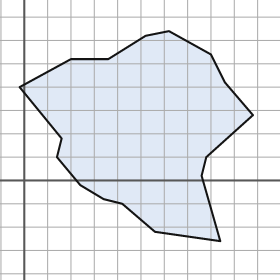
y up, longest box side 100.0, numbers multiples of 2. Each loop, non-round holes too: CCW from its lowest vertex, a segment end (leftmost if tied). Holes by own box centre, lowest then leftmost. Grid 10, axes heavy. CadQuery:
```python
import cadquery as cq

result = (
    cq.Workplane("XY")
    .moveTo(84.0, -26.0)
    .lineTo(76.0, 2.0)
    .lineTo(78.0, 10.0)
    .lineTo(98.0, 28.0)
    .lineTo(86.0, 42.0)
    .lineTo(80.0, 54.0)
    .lineTo(62.0, 64.0)
    .lineTo(52.0, 62.0)
    .lineTo(36.0, 52.0)
    .lineTo(20.0, 52.0)
    .lineTo(-2.0, 40.0)
    .lineTo(16.0, 18.0)
    .lineTo(14.0, 10.0)
    .lineTo(24.0, -2.0)
    .lineTo(34.0, -8.0)
    .lineTo(42.0, -10.0)
    .lineTo(56.0, -22.0)
    .close()
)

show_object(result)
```